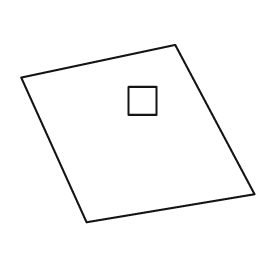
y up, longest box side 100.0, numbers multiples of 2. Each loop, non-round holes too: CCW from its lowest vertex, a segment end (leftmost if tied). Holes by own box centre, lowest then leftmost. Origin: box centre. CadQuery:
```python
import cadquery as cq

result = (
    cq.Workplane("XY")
    .moveTo(-22.0, -38.0)
    .lineTo(50.0, -26.0)
    .lineTo(16.0, 38.0)
    .lineTo(-50.0, 24.0)
    .close()
    .moveTo(-4.0, 8.0)
    .lineTo(8.0, 8.0)
    .lineTo(8.0, 20.0)
    .lineTo(-4.0, 20.0)
    .close()
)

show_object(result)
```